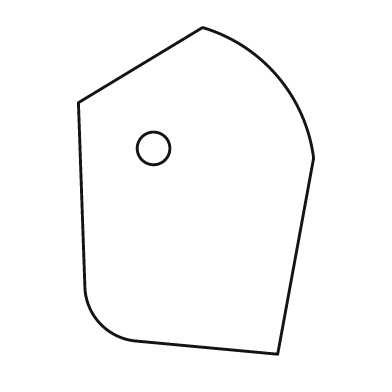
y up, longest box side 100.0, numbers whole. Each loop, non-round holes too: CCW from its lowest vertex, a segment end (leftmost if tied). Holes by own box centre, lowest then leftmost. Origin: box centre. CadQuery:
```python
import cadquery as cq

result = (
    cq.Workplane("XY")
    .moveTo(25.0, -50.0)
    .lineTo(36.0, 10.0)
    .threePointArc((25.0, 35.0), (2.0, 50.0))
    .lineTo(-36.0, 27.0)
    .lineTo(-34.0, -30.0)
    .threePointArc((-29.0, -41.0), (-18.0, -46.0))
    .close()
    .moveTo(-13.0, 13.0)
    .circle(5.0)
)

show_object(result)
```